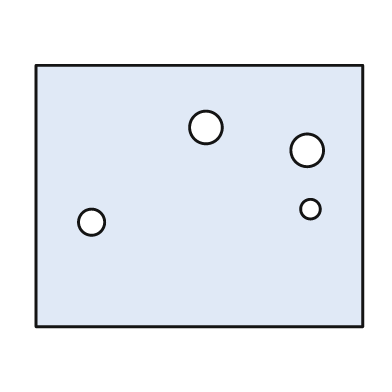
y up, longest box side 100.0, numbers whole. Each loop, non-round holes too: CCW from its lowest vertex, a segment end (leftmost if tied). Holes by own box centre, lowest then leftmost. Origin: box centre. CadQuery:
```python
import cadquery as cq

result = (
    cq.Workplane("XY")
    .moveTo(-50.0, -40.0)
    .lineTo(50.0, -40.0)
    .lineTo(50.0, 40.0)
    .lineTo(-50.0, 40.0)
    .close()
    .moveTo(-33.0, -8.0)
    .circle(4.0)
    .moveTo(34.0, -4.0)
    .circle(3.0)
    .moveTo(33.0, 14.0)
    .circle(5.0)
    .moveTo(2.0, 21.0)
    .circle(5.0)
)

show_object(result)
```